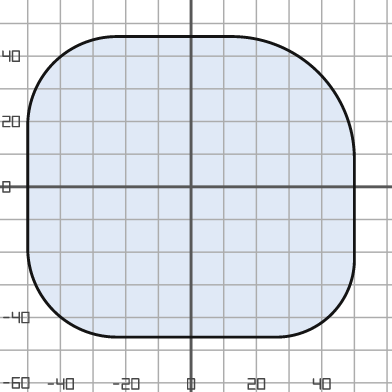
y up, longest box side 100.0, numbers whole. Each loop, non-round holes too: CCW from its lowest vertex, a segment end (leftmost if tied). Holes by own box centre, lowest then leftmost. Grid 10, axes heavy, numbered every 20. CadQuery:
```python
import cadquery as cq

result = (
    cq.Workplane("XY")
    .moveTo(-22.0, -46.0)
    .lineTo(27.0, -46.0)
    .threePointArc((43.0, -39.0), (50.0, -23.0))
    .lineTo(50.0, 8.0)
    .threePointArc((39.0, 35.0), (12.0, 46.0))
    .lineTo(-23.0, 46.0)
    .threePointArc((-42.0, 38.0), (-50.0, 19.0))
    .lineTo(-50.0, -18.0)
    .threePointArc((-42.0, -38.0), (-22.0, -46.0))
    .close()
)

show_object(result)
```